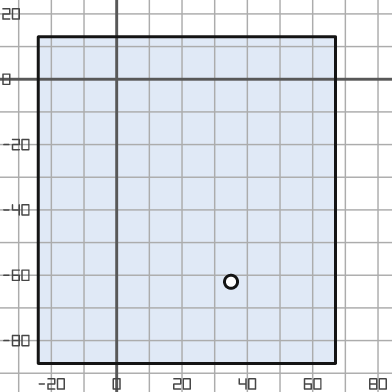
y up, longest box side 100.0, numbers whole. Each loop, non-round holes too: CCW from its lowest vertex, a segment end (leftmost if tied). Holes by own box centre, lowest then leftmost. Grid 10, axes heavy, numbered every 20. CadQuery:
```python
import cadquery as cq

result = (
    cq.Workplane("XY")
    .moveTo(-24.0, -87.0)
    .lineTo(67.0, -87.0)
    .lineTo(67.0, 13.0)
    .lineTo(-24.0, 13.0)
    .close()
    .moveTo(35.0, -62.0)
    .circle(2.0)
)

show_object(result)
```